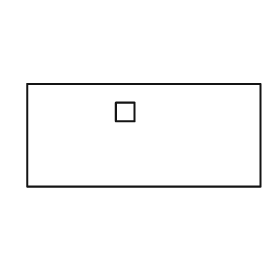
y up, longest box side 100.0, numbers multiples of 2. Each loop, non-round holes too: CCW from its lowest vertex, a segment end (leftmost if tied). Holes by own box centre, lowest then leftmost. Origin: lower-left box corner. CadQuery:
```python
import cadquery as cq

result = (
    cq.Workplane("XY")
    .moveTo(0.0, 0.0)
    .lineTo(100.0, 0.0)
    .lineTo(100.0, 44.0)
    .lineTo(0.0, 44.0)
    .close()
    .moveTo(38.0, 28.0)
    .lineTo(46.0, 28.0)
    .lineTo(46.0, 36.0)
    .lineTo(38.0, 36.0)
    .close()
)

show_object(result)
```